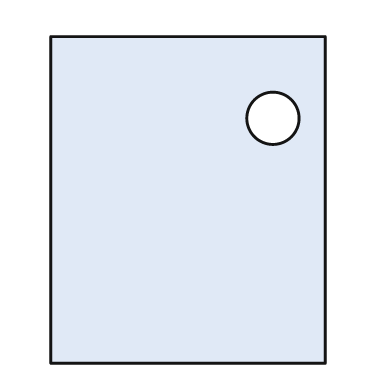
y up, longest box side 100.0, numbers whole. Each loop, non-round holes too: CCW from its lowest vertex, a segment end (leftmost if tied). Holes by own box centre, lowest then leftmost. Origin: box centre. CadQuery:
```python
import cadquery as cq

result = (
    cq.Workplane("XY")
    .moveTo(-42.0, -50.0)
    .lineTo(42.0, -50.0)
    .lineTo(42.0, 50.0)
    .lineTo(-42.0, 50.0)
    .close()
    .moveTo(26.0, 25.0)
    .circle(8.0)
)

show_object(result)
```